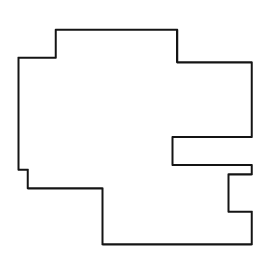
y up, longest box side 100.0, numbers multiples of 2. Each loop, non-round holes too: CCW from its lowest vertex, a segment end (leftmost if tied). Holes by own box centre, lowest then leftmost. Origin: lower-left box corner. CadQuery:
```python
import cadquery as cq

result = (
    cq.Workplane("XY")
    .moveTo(36.0, 0.0)
    .lineTo(100.0, 0.0)
    .lineTo(100.0, 14.0)
    .lineTo(90.0, 14.0)
    .lineTo(90.0, 30.0)
    .lineTo(100.0, 30.0)
    .lineTo(100.0, 34.0)
    .lineTo(66.0, 34.0)
    .lineTo(66.0, 46.0)
    .lineTo(100.0, 46.0)
    .lineTo(100.0, 78.0)
    .lineTo(68.0, 78.0)
    .lineTo(68.0, 92.0)
    .lineTo(16.0, 92.0)
    .lineTo(16.0, 80.0)
    .lineTo(0.0, 80.0)
    .lineTo(0.0, 32.0)
    .lineTo(4.0, 32.0)
    .lineTo(4.0, 24.0)
    .lineTo(36.0, 24.0)
    .close()
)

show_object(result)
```